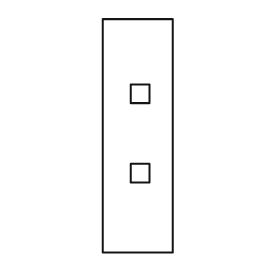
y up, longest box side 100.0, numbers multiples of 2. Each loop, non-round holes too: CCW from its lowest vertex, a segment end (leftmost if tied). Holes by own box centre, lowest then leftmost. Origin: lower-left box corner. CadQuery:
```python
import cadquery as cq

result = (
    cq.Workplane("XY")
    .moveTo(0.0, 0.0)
    .lineTo(30.0, 0.0)
    .lineTo(30.0, 100.0)
    .lineTo(0.0, 100.0)
    .close()
    .moveTo(12.0, 30.0)
    .lineTo(20.0, 30.0)
    .lineTo(20.0, 38.0)
    .lineTo(12.0, 38.0)
    .close()
    .moveTo(12.0, 64.0)
    .lineTo(20.0, 64.0)
    .lineTo(20.0, 72.0)
    .lineTo(12.0, 72.0)
    .close()
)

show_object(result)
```